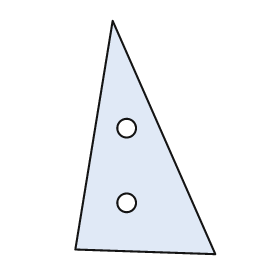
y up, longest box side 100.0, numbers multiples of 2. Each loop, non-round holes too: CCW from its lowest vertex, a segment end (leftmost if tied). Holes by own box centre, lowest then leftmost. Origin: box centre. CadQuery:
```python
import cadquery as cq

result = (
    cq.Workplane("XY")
    .moveTo(30.0, -50.0)
    .lineTo(-14.0, 50.0)
    .lineTo(-30.0, -48.0)
    .close()
    .moveTo(-8.0, -28.0)
    .circle(4.0)
    .moveTo(-8.0, 4.0)
    .circle(4.0)
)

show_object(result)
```